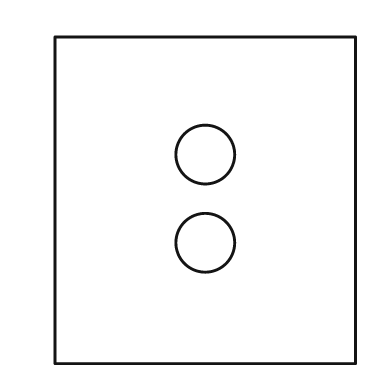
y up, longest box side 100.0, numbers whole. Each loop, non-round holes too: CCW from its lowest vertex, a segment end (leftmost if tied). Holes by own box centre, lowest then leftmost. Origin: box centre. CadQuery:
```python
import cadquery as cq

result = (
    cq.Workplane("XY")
    .moveTo(-46.0, -50.0)
    .lineTo(46.0, -50.0)
    .lineTo(46.0, 50.0)
    .lineTo(-46.0, 50.0)
    .close()
    .moveTo(0.0, -13.0)
    .circle(9.0)
    .moveTo(0.0, 14.0)
    .circle(9.0)
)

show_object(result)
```